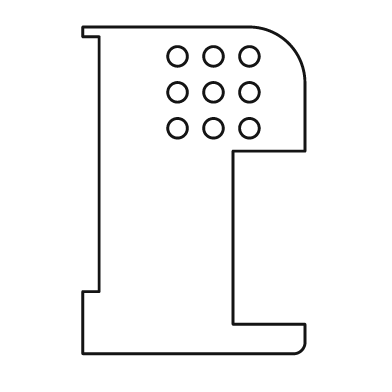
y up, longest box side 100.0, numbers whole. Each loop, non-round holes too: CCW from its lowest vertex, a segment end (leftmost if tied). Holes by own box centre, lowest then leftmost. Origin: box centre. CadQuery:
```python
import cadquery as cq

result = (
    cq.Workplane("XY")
    .moveTo(-34.0, -50.0)
    .lineTo(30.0, -50.0)
    .threePointArc((33.0, -49.0), (34.0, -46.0))
    .lineTo(34.0, -41.0)
    .lineTo(12.0, -41.0)
    .lineTo(12.0, 12.0)
    .lineTo(34.0, 12.0)
    .lineTo(34.0, 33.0)
    .threePointArc((29.0, 45.0), (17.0, 50.0))
    .lineTo(-34.0, 50.0)
    .lineTo(-34.0, 47.0)
    .lineTo(-29.0, 47.0)
    .lineTo(-29.0, -31.0)
    .lineTo(-34.0, -31.0)
    .close()
    .moveTo(-5.0, 19.0)
    .circle(3.0)
    .moveTo(6.0, 19.0)
    .circle(3.0)
    .moveTo(17.0, 19.0)
    .circle(3.0)
    .moveTo(-5.0, 30.0)
    .circle(3.0)
    .moveTo(6.0, 30.0)
    .circle(3.0)
    .moveTo(17.0, 30.0)
    .circle(3.0)
    .moveTo(-5.0, 41.0)
    .circle(3.0)
    .moveTo(6.0, 41.0)
    .circle(3.0)
    .moveTo(17.0, 41.0)
    .circle(3.0)
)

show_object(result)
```